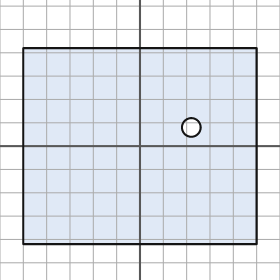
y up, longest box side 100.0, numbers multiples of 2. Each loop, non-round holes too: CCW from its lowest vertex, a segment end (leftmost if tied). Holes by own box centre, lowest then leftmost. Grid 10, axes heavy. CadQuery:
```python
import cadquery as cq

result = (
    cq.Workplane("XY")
    .moveTo(-50.0, -42.0)
    .lineTo(50.0, -42.0)
    .lineTo(50.0, 42.0)
    .lineTo(-50.0, 42.0)
    .close()
    .moveTo(22.0, 8.0)
    .circle(4.0)
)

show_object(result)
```